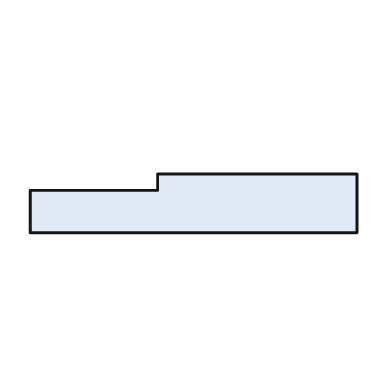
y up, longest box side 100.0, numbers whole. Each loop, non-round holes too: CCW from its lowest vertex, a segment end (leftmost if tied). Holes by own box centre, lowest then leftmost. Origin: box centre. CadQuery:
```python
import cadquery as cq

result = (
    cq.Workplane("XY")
    .moveTo(-50.0, -9.0)
    .lineTo(50.0, -9.0)
    .lineTo(50.0, 9.0)
    .lineTo(-11.0, 9.0)
    .lineTo(-11.0, 4.0)
    .lineTo(-50.0, 4.0)
    .close()
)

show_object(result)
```